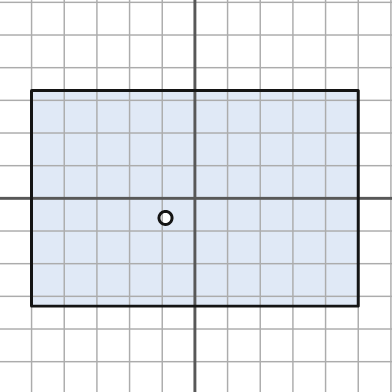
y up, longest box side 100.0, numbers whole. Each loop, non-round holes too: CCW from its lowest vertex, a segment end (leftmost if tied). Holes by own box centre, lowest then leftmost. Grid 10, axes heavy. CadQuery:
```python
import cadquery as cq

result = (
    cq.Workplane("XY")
    .moveTo(-50.0, -33.0)
    .lineTo(50.0, -33.0)
    .lineTo(50.0, 33.0)
    .lineTo(-50.0, 33.0)
    .close()
    .moveTo(-9.0, -6.0)
    .circle(2.0)
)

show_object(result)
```